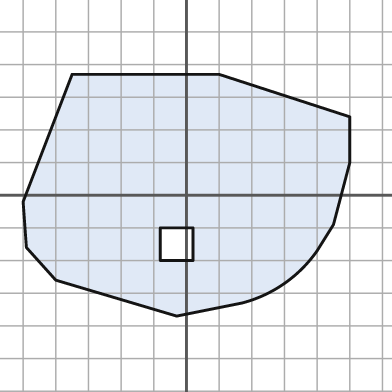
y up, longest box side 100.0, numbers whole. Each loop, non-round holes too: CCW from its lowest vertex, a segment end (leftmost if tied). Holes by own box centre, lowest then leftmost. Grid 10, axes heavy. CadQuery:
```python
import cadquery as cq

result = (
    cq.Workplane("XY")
    .moveTo(-3.0, -37.0)
    .lineTo(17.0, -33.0)
    .threePointArc((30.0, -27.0), (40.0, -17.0))
    .lineTo(45.0, -9.0)
    .lineTo(50.0, 10.0)
    .lineTo(50.0, 24.0)
    .lineTo(10.0, 37.0)
    .lineTo(-35.0, 37.0)
    .lineTo(-50.0, -2.0)
    .lineTo(-49.0, -16.0)
    .lineTo(-40.0, -26.0)
    .close()
    .moveTo(-8.0, -20.0)
    .lineTo(2.0, -20.0)
    .lineTo(2.0, -10.0)
    .lineTo(-8.0, -10.0)
    .close()
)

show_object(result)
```